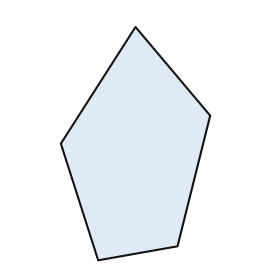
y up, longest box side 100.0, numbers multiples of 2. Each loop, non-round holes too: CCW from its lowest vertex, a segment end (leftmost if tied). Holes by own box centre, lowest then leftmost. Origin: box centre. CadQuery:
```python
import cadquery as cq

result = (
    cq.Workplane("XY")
    .moveTo(-16.0, -50.0)
    .lineTo(18.0, -44.0)
    .lineTo(32.0, 12.0)
    .lineTo(0.0, 50.0)
    .lineTo(-32.0, 0.0)
    .close()
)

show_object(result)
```